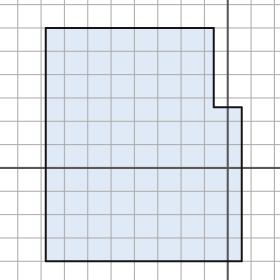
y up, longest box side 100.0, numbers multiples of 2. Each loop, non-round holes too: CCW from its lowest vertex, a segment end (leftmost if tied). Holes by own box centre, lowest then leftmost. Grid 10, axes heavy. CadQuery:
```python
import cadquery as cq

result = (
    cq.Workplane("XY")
    .moveTo(-78.0, -40.0)
    .lineTo(6.0, -40.0)
    .lineTo(6.0, 26.0)
    .lineTo(-6.0, 26.0)
    .lineTo(-6.0, 60.0)
    .lineTo(-78.0, 60.0)
    .close()
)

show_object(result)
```